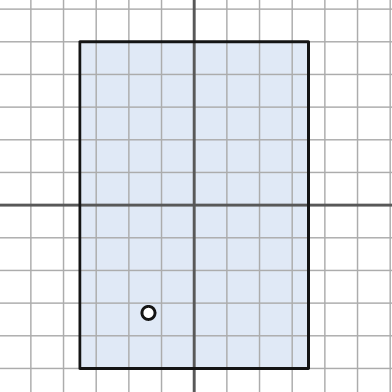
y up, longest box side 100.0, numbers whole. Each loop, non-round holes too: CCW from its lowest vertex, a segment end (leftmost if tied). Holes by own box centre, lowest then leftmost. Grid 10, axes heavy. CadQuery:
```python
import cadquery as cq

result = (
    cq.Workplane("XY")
    .moveTo(-35.0, -50.0)
    .lineTo(35.0, -50.0)
    .lineTo(35.0, 50.0)
    .lineTo(-35.0, 50.0)
    .close()
    .moveTo(-14.0, -33.0)
    .circle(2.0)
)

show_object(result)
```